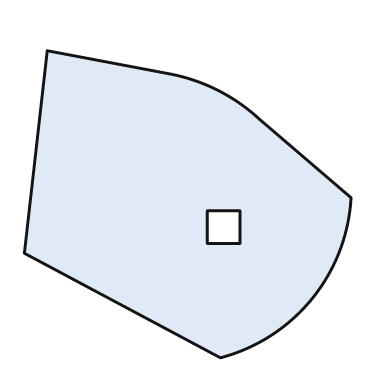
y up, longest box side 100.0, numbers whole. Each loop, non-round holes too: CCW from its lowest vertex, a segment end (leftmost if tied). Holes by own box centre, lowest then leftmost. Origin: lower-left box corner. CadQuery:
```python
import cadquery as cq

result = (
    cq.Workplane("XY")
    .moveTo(60.0, 0.0)
    .threePointArc((88.0, 18.0), (100.0, 49.0))
    .lineTo(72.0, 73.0)
    .threePointArc((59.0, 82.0), (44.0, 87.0))
    .lineTo(7.0, 94.0)
    .lineTo(0.0, 32.0)
    .close()
    .moveTo(56.0, 35.0)
    .lineTo(66.0, 35.0)
    .lineTo(66.0, 45.0)
    .lineTo(56.0, 45.0)
    .close()
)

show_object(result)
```